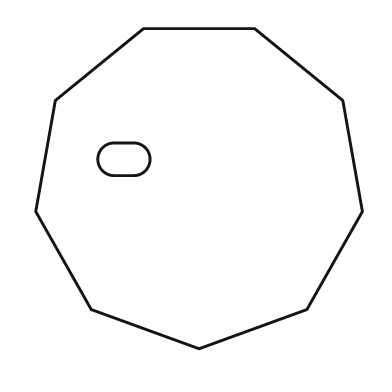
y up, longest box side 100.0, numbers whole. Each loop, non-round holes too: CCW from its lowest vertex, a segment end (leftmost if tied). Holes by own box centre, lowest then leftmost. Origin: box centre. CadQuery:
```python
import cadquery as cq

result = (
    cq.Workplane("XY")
    .moveTo(0.0, -49.0)
    .lineTo(33.0, -37.0)
    .lineTo(50.0, -7.0)
    .lineTo(44.0, 27.0)
    .lineTo(17.0, 49.0)
    .lineTo(-17.0, 49.0)
    .lineTo(-44.0, 27.0)
    .lineTo(-50.0, -7.0)
    .lineTo(-33.0, -37.0)
    .close()
    .moveTo(-26.0, 4.0)
    .lineTo(-20.0, 4.0)
    .threePointArc((-15.0, 9.0), (-20.0, 14.0))
    .lineTo(-26.0, 14.0)
    .threePointArc((-31.0, 9.0), (-26.0, 4.0))
    .close()
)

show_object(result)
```